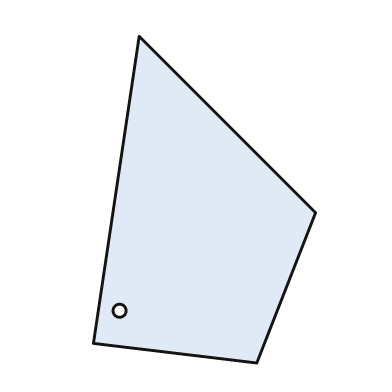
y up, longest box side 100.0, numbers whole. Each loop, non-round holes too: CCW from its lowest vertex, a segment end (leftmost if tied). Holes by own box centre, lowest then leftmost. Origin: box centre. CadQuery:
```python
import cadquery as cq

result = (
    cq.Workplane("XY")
    .moveTo(16.0, -50.0)
    .lineTo(34.0, -4.0)
    .lineTo(-20.0, 50.0)
    .lineTo(-34.0, -44.0)
    .close()
    .moveTo(-26.0, -34.0)
    .circle(2.0)
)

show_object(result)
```